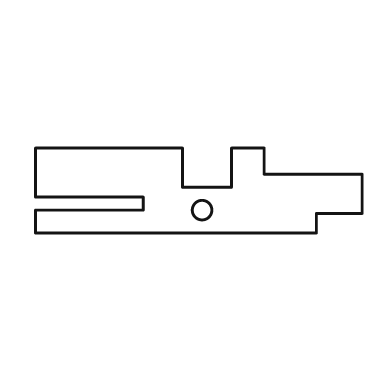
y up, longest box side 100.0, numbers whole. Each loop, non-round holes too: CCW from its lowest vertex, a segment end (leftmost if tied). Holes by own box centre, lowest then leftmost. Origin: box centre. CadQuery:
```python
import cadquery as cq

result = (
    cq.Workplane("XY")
    .moveTo(-50.0, -13.0)
    .lineTo(36.0, -13.0)
    .lineTo(36.0, -7.0)
    .lineTo(50.0, -7.0)
    .lineTo(50.0, 5.0)
    .lineTo(20.0, 5.0)
    .lineTo(20.0, 13.0)
    .lineTo(10.0, 13.0)
    .lineTo(10.0, 1.0)
    .lineTo(-5.0, 1.0)
    .lineTo(-5.0, 13.0)
    .lineTo(-50.0, 13.0)
    .lineTo(-50.0, -2.0)
    .lineTo(-17.0, -2.0)
    .lineTo(-17.0, -6.0)
    .lineTo(-50.0, -6.0)
    .close()
    .moveTo(1.0, -6.0)
    .circle(3.0)
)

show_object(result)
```